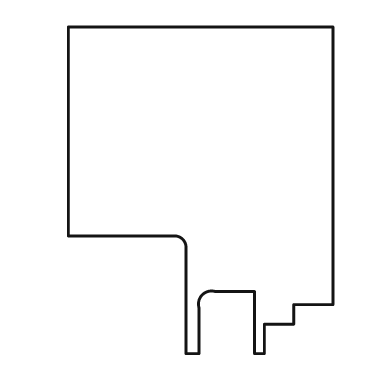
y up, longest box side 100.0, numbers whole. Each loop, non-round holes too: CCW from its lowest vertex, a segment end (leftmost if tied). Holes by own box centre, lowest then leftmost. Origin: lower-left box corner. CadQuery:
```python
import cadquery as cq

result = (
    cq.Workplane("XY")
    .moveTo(36.0, 0.0)
    .lineTo(40.0, 0.0)
    .lineTo(40.0, 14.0)
    .threePointArc((41.0, 18.0), (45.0, 19.0))
    .lineTo(57.0, 19.0)
    .lineTo(57.0, 0.0)
    .lineTo(60.0, 0.0)
    .lineTo(60.0, 9.0)
    .lineTo(69.0, 9.0)
    .lineTo(69.0, 15.0)
    .lineTo(81.0, 15.0)
    .lineTo(81.0, 100.0)
    .lineTo(0.0, 100.0)
    .lineTo(0.0, 36.0)
    .lineTo(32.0, 36.0)
    .threePointArc((35.0, 35.0), (36.0, 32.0))
    .close()
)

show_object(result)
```